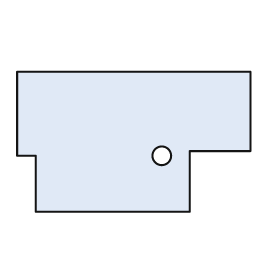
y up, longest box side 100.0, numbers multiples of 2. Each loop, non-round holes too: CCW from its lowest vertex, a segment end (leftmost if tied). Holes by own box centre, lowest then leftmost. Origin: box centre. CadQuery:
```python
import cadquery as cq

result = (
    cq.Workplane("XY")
    .moveTo(-42.0, -30.0)
    .lineTo(24.0, -30.0)
    .lineTo(24.0, -4.0)
    .lineTo(50.0, -4.0)
    .lineTo(50.0, 30.0)
    .lineTo(-50.0, 30.0)
    .lineTo(-50.0, -6.0)
    .lineTo(-42.0, -6.0)
    .close()
    .moveTo(12.0, -6.0)
    .circle(4.0)
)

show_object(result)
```